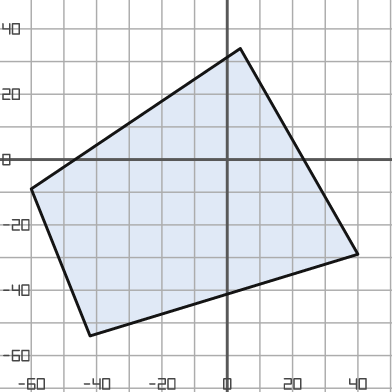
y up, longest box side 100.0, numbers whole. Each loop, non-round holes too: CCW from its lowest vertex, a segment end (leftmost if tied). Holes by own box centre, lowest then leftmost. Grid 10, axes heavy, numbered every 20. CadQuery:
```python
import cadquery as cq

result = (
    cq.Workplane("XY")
    .moveTo(-42.0, -54.0)
    .lineTo(40.0, -29.0)
    .lineTo(4.0, 34.0)
    .lineTo(-60.0, -9.0)
    .close()
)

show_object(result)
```